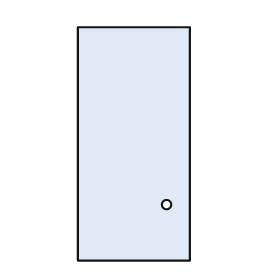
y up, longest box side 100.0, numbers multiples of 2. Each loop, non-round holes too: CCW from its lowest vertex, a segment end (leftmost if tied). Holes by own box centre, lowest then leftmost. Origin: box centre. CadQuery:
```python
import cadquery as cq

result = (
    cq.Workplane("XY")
    .moveTo(-24.0, -50.0)
    .lineTo(24.0, -50.0)
    .lineTo(24.0, 50.0)
    .lineTo(-24.0, 50.0)
    .close()
    .moveTo(14.0, -26.0)
    .circle(2.0)
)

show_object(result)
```